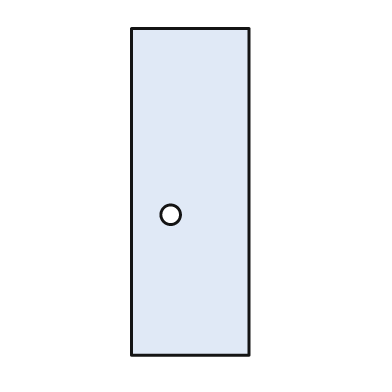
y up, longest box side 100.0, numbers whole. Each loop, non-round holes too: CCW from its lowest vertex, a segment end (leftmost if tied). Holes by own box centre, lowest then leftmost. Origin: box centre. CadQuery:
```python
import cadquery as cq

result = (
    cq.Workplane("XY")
    .moveTo(-18.0, -50.0)
    .lineTo(18.0, -50.0)
    .lineTo(18.0, 50.0)
    .lineTo(-18.0, 50.0)
    .close()
    .moveTo(-6.0, -7.0)
    .circle(3.0)
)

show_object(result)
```